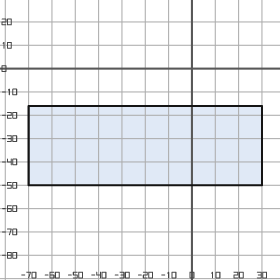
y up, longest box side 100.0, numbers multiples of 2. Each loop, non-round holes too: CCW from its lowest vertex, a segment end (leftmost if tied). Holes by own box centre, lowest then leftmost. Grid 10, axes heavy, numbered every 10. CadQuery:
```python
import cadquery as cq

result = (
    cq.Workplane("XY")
    .moveTo(-70.0, -50.0)
    .lineTo(30.0, -50.0)
    .lineTo(30.0, -16.0)
    .lineTo(-70.0, -16.0)
    .close()
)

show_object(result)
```